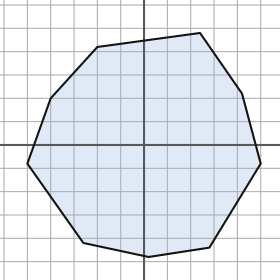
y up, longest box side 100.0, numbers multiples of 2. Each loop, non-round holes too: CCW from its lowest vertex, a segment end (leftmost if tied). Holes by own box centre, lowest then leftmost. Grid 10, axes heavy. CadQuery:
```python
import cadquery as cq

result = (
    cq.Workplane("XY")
    .moveTo(2.0, -48.0)
    .lineTo(28.0, -44.0)
    .lineTo(50.0, -8.0)
    .lineTo(42.0, 22.0)
    .lineTo(24.0, 48.0)
    .lineTo(-20.0, 42.0)
    .lineTo(-40.0, 20.0)
    .lineTo(-50.0, -8.0)
    .lineTo(-26.0, -42.0)
    .close()
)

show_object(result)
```